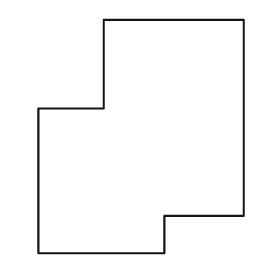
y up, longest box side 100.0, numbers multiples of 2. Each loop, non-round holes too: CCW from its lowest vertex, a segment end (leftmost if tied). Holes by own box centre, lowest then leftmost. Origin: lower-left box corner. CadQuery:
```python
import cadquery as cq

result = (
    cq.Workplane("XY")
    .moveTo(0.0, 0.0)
    .lineTo(54.0, 0.0)
    .lineTo(54.0, 16.0)
    .lineTo(88.0, 16.0)
    .lineTo(88.0, 100.0)
    .lineTo(28.0, 100.0)
    .lineTo(28.0, 62.0)
    .lineTo(0.0, 62.0)
    .close()
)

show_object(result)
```